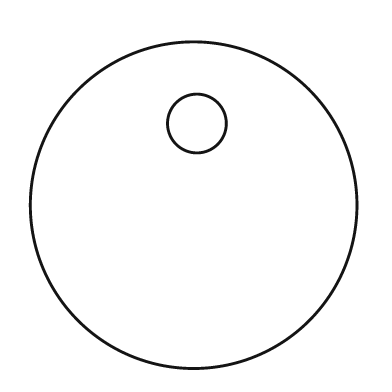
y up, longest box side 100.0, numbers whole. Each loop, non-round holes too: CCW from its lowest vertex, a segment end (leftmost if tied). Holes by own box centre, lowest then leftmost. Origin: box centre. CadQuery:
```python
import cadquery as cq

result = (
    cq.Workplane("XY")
    .moveTo(0.0, 0.0)
    .circle(50.0)
    .moveTo(1.0, 25.0)
    .circle(9.0)
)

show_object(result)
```